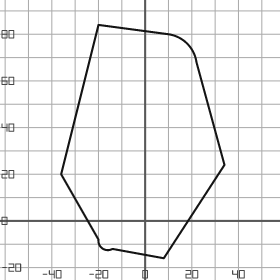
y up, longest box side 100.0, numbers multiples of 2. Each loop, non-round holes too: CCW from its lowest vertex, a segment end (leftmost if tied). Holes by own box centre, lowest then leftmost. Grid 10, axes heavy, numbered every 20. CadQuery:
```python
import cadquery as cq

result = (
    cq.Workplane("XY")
    .moveTo(8.0, -16.0)
    .lineTo(34.0, 24.0)
    .lineTo(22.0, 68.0)
    .threePointArc((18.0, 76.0), (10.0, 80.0))
    .lineTo(-20.0, 84.0)
    .lineTo(-36.0, 20.0)
    .lineTo(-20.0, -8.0)
    .threePointArc((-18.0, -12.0), (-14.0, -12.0))
    .close()
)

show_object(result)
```